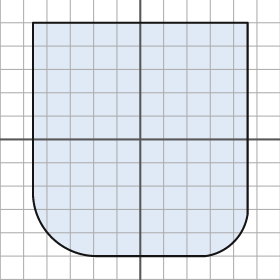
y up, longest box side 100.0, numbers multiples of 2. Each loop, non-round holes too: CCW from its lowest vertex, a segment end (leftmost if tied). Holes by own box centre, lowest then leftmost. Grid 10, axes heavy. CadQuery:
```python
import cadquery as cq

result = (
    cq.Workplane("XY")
    .moveTo(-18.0, -50.0)
    .lineTo(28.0, -50.0)
    .threePointArc((40.0, -44.0), (46.0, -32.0))
    .lineTo(46.0, 50.0)
    .lineTo(-46.0, 50.0)
    .lineTo(-46.0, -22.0)
    .threePointArc((-38.0, -42.0), (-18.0, -50.0))
    .close()
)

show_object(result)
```